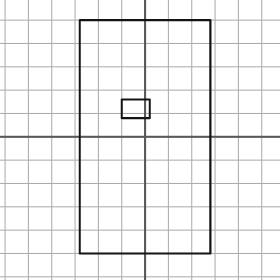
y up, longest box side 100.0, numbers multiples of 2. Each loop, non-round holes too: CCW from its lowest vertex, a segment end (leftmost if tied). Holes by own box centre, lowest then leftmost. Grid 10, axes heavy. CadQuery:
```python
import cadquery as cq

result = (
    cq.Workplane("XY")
    .moveTo(-28.0, -50.0)
    .lineTo(28.0, -50.0)
    .lineTo(28.0, 50.0)
    .lineTo(-28.0, 50.0)
    .close()
    .moveTo(-10.0, 8.0)
    .lineTo(2.0, 8.0)
    .lineTo(2.0, 16.0)
    .lineTo(-10.0, 16.0)
    .close()
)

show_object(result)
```